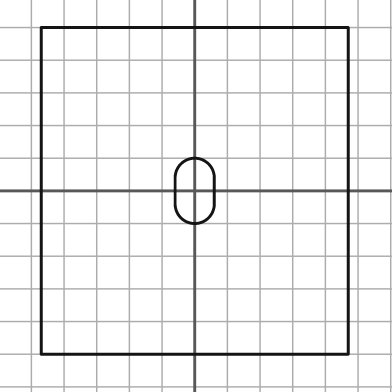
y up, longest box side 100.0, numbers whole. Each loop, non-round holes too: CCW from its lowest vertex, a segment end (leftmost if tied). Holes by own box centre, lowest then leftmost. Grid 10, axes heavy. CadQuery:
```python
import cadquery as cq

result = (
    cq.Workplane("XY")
    .moveTo(-47.0, -50.0)
    .lineTo(47.0, -50.0)
    .lineTo(47.0, 50.0)
    .lineTo(-47.0, 50.0)
    .close()
    .moveTo(-6.0, -4.0)
    .threePointArc((0.0, -10.0), (6.0, -4.0))
    .lineTo(6.0, 4.0)
    .threePointArc((0.0, 10.0), (-6.0, 4.0))
    .close()
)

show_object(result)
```